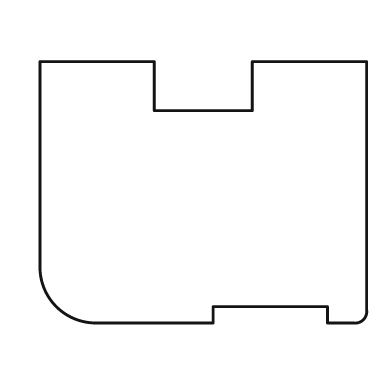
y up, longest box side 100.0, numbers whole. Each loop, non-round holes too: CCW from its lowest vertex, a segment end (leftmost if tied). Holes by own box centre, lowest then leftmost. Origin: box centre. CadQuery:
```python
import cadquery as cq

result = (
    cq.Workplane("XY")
    .moveTo(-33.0, -40.0)
    .lineTo(3.0, -40.0)
    .lineTo(3.0, -35.0)
    .lineTo(38.0, -35.0)
    .lineTo(38.0, -40.0)
    .lineTo(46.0, -40.0)
    .threePointArc((49.0, -39.0), (50.0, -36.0))
    .lineTo(50.0, 40.0)
    .lineTo(15.0, 40.0)
    .lineTo(15.0, 25.0)
    .lineTo(-15.0, 25.0)
    .lineTo(-15.0, 40.0)
    .lineTo(-50.0, 40.0)
    .lineTo(-50.0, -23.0)
    .threePointArc((-45.0, -35.0), (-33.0, -40.0))
    .close()
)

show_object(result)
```